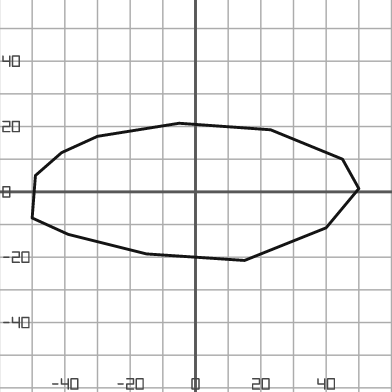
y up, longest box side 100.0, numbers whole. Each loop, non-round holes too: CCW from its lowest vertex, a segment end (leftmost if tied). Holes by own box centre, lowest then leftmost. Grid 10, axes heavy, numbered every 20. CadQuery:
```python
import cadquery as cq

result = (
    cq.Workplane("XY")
    .moveTo(15.0, -21.0)
    .lineTo(40.0, -11.0)
    .lineTo(50.0, 1.0)
    .lineTo(45.0, 10.0)
    .lineTo(23.0, 19.0)
    .lineTo(-5.0, 21.0)
    .lineTo(-30.0, 17.0)
    .lineTo(-41.0, 12.0)
    .lineTo(-49.0, 5.0)
    .lineTo(-50.0, -8.0)
    .lineTo(-39.0, -13.0)
    .lineTo(-15.0, -19.0)
    .close()
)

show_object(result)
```